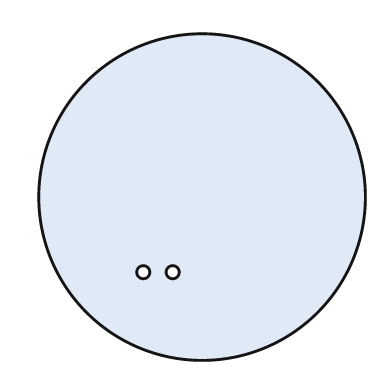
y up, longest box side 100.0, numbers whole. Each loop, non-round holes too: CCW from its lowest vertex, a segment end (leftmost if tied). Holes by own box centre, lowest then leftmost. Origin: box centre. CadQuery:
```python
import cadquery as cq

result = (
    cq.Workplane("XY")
    .moveTo(0.0, 0.0)
    .circle(50.0)
    .moveTo(-18.0, -23.0)
    .circle(2.0)
    .moveTo(-9.0, -23.0)
    .circle(2.0)
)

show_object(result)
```